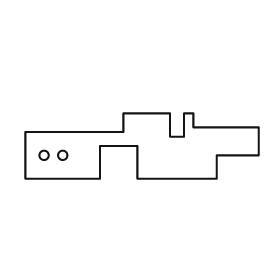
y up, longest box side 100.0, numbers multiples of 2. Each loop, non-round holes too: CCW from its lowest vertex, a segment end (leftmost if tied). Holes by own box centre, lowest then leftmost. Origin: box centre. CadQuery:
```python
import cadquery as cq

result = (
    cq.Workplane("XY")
    .moveTo(-50.0, -14.0)
    .lineTo(-18.0, -14.0)
    .lineTo(-18.0, 0.0)
    .lineTo(-2.0, 0.0)
    .lineTo(-2.0, -14.0)
    .lineTo(32.0, -14.0)
    .lineTo(32.0, -4.0)
    .lineTo(50.0, -4.0)
    .lineTo(50.0, 8.0)
    .lineTo(22.0, 8.0)
    .lineTo(22.0, 14.0)
    .lineTo(18.0, 14.0)
    .lineTo(18.0, 4.0)
    .lineTo(12.0, 4.0)
    .lineTo(12.0, 14.0)
    .lineTo(-8.0, 14.0)
    .lineTo(-8.0, 6.0)
    .lineTo(-50.0, 6.0)
    .close()
    .moveTo(-42.0, -4.0)
    .circle(2.0)
    .moveTo(-34.0, -4.0)
    .circle(2.0)
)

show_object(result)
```